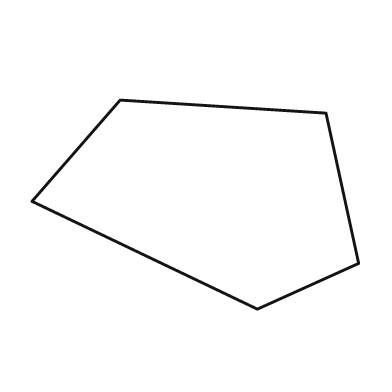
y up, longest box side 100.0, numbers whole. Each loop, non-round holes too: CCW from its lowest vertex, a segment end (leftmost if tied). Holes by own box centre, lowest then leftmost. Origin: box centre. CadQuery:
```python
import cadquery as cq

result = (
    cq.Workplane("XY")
    .moveTo(19.0, -32.0)
    .lineTo(50.0, -18.0)
    .lineTo(40.0, 28.0)
    .lineTo(-23.0, 32.0)
    .lineTo(-50.0, 1.0)
    .close()
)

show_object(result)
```